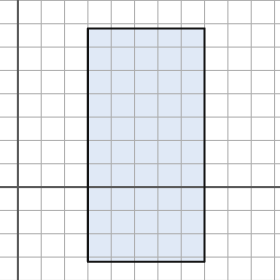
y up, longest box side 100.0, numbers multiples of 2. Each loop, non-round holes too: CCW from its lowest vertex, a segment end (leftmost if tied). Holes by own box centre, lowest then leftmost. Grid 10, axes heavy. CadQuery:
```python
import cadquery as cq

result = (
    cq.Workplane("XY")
    .moveTo(30.0, -32.0)
    .lineTo(80.0, -32.0)
    .lineTo(80.0, 68.0)
    .lineTo(30.0, 68.0)
    .close()
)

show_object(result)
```